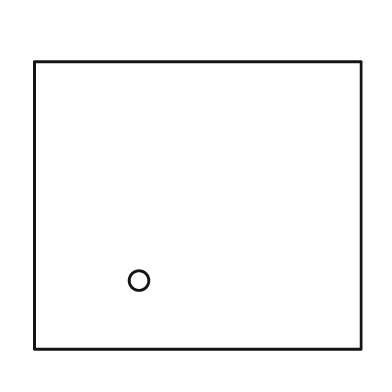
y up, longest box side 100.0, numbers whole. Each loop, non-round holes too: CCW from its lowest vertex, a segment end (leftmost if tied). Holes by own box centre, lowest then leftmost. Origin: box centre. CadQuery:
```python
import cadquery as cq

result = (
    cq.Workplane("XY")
    .moveTo(-50.0, -44.0)
    .lineTo(50.0, -44.0)
    .lineTo(50.0, 44.0)
    .lineTo(-50.0, 44.0)
    .close()
    .moveTo(-18.0, -23.0)
    .circle(3.0)
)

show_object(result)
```